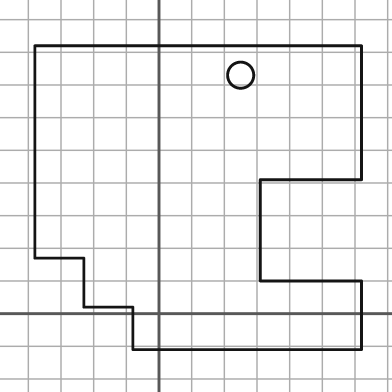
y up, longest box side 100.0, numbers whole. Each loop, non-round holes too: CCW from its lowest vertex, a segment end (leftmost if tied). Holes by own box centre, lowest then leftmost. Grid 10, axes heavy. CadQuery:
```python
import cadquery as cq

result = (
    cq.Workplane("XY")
    .moveTo(-8.0, -11.0)
    .lineTo(62.0, -11.0)
    .lineTo(62.0, 10.0)
    .lineTo(31.0, 10.0)
    .lineTo(31.0, 41.0)
    .lineTo(62.0, 41.0)
    .lineTo(62.0, 82.0)
    .lineTo(-38.0, 82.0)
    .lineTo(-38.0, 17.0)
    .lineTo(-23.0, 17.0)
    .lineTo(-23.0, 2.0)
    .lineTo(-8.0, 2.0)
    .close()
    .moveTo(25.0, 73.0)
    .circle(4.0)
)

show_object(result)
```